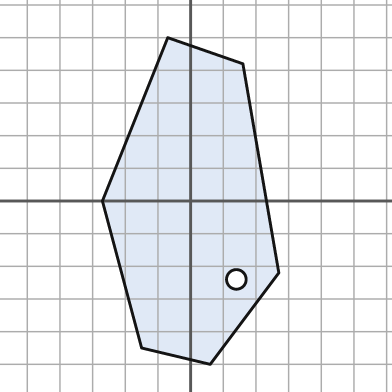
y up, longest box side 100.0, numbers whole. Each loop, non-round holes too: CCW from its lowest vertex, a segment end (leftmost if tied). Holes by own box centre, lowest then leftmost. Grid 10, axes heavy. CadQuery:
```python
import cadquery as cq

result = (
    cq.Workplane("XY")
    .moveTo(6.0, -50.0)
    .lineTo(27.0, -22.0)
    .lineTo(16.0, 42.0)
    .lineTo(-7.0, 50.0)
    .lineTo(-27.0, 0.0)
    .lineTo(-15.0, -45.0)
    .close()
    .moveTo(14.0, -24.0)
    .circle(3.0)
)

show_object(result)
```